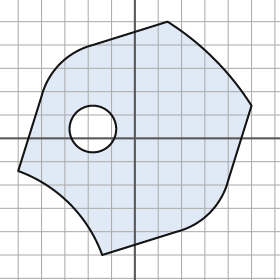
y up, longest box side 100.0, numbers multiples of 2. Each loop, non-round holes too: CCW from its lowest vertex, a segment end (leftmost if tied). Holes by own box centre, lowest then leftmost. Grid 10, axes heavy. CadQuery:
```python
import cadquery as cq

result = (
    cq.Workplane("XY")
    .moveTo(-14.0, -50.0)
    .lineTo(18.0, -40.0)
    .threePointArc((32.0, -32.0), (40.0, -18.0))
    .lineTo(50.0, 14.0)
    .threePointArc((34.0, 34.0), (14.0, 50.0))
    .lineTo(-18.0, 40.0)
    .threePointArc((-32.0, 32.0), (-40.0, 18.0))
    .lineTo(-50.0, -14.0)
    .threePointArc((-28.0, -28.0), (-14.0, -50.0))
    .close()
    .moveTo(-18.0, 4.0)
    .circle(10.0)
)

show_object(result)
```